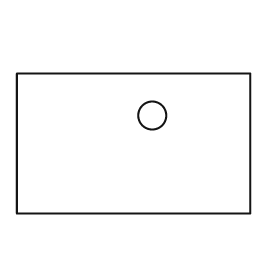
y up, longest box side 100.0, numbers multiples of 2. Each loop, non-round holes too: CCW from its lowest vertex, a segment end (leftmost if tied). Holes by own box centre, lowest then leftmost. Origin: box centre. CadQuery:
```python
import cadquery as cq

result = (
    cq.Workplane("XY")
    .moveTo(-50.0, -30.0)
    .lineTo(50.0, -30.0)
    .lineTo(50.0, 30.0)
    .lineTo(-50.0, 30.0)
    .close()
    .moveTo(8.0, 12.0)
    .circle(6.0)
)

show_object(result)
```